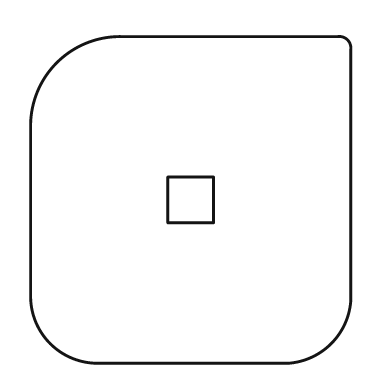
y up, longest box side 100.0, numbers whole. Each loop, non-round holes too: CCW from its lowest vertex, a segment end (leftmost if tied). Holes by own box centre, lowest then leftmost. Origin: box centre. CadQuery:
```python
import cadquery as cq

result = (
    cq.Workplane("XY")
    .moveTo(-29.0, -50.0)
    .lineTo(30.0, -50.0)
    .threePointArc((43.0, -44.0), (49.0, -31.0))
    .lineTo(49.0, 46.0)
    .threePointArc((48.0, 49.0), (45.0, 50.0))
    .lineTo(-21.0, 50.0)
    .threePointArc((-41.0, 42.0), (-49.0, 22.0))
    .lineTo(-49.0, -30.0)
    .threePointArc((-43.0, -44.0), (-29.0, -50.0))
    .close()
    .moveTo(-7.0, -7.0)
    .lineTo(7.0, -7.0)
    .lineTo(7.0, 7.0)
    .lineTo(-7.0, 7.0)
    .close()
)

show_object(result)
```